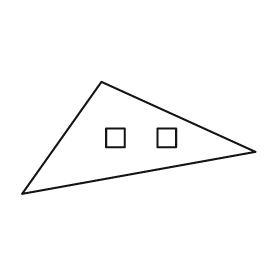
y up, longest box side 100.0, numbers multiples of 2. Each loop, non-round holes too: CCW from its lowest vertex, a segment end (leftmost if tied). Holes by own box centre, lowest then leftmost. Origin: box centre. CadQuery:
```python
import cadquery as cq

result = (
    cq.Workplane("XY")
    .moveTo(-50.0, -24.0)
    .lineTo(50.0, -6.0)
    .lineTo(-16.0, 24.0)
    .close()
    .moveTo(-14.0, -4.0)
    .lineTo(-6.0, -4.0)
    .lineTo(-6.0, 4.0)
    .lineTo(-14.0, 4.0)
    .close()
    .moveTo(8.0, -4.0)
    .lineTo(16.0, -4.0)
    .lineTo(16.0, 4.0)
    .lineTo(8.0, 4.0)
    .close()
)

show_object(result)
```